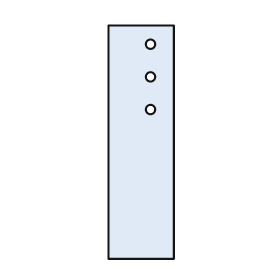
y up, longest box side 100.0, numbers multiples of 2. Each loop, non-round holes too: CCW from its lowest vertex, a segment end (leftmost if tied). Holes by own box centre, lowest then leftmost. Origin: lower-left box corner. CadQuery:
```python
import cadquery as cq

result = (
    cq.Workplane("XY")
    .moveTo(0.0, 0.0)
    .lineTo(28.0, 0.0)
    .lineTo(28.0, 100.0)
    .lineTo(0.0, 100.0)
    .close()
    .moveTo(18.0, 64.0)
    .circle(2.0)
    .moveTo(18.0, 78.0)
    .circle(2.0)
    .moveTo(18.0, 92.0)
    .circle(2.0)
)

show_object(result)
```